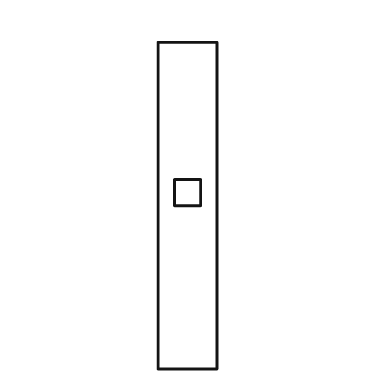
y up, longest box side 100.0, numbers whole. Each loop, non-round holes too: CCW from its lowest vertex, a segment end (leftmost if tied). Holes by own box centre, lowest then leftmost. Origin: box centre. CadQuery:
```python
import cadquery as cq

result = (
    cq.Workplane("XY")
    .moveTo(-9.0, -50.0)
    .lineTo(9.0, -50.0)
    .lineTo(9.0, 50.0)
    .lineTo(-9.0, 50.0)
    .close()
    .moveTo(-4.0, 0.0)
    .lineTo(4.0, 0.0)
    .lineTo(4.0, 8.0)
    .lineTo(-4.0, 8.0)
    .close()
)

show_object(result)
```